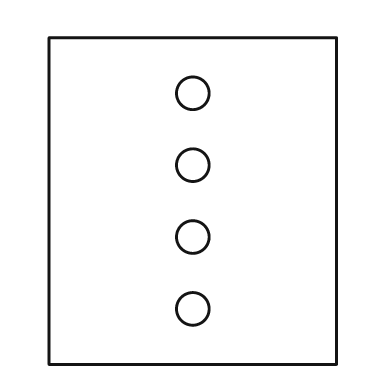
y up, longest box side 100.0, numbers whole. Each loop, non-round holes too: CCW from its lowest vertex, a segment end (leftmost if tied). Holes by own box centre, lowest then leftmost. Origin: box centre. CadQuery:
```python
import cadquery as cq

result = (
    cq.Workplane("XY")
    .moveTo(-44.0, -50.0)
    .lineTo(44.0, -50.0)
    .lineTo(44.0, 50.0)
    .lineTo(-44.0, 50.0)
    .close()
    .moveTo(0.0, -33.0)
    .circle(5.0)
    .moveTo(0.0, -11.0)
    .circle(5.0)
    .moveTo(0.0, 11.0)
    .circle(5.0)
    .moveTo(0.0, 33.0)
    .circle(5.0)
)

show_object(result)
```